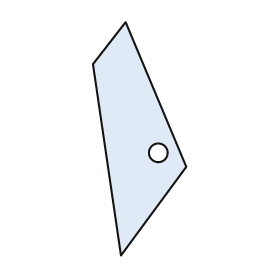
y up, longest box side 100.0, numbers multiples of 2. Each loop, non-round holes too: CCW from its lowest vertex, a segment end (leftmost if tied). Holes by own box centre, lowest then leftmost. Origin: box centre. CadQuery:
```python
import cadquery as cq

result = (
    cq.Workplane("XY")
    .moveTo(-8.0, -50.0)
    .lineTo(20.0, -12.0)
    .lineTo(-6.0, 50.0)
    .lineTo(-20.0, 32.0)
    .close()
    .moveTo(8.0, -6.0)
    .circle(4.0)
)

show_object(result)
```